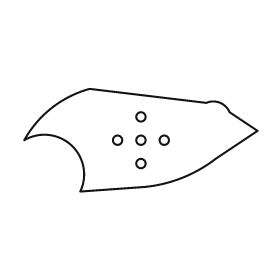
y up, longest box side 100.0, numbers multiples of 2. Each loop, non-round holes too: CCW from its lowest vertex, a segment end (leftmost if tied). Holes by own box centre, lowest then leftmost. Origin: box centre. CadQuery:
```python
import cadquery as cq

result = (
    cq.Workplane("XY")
    .moveTo(-26.0, -22.0)
    .lineTo(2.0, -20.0)
    .threePointArc((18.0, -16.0), (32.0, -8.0))
    .lineTo(50.0, 4.0)
    .lineTo(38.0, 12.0)
    .threePointArc((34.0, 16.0), (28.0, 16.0))
    .lineTo(-22.0, 22.0)
    .threePointArc((-38.0, 14.0), (-50.0, 0.0))
    .threePointArc((-30.0, -2.0), (-26.0, -22.0))
    .close()
    .moveTo(0.0, -10.0)
    .circle(2.0)
    .moveTo(-10.0, 0.0)
    .circle(2.0)
    .moveTo(0.0, 0.0)
    .circle(2.0)
    .moveTo(10.0, 0.0)
    .circle(2.0)
    .moveTo(0.0, 10.0)
    .circle(2.0)
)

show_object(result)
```